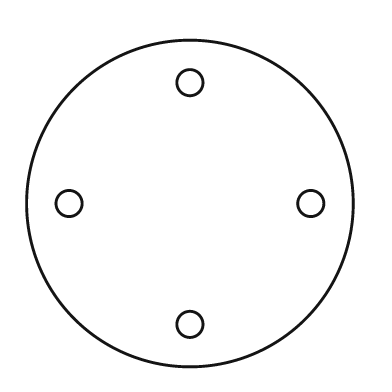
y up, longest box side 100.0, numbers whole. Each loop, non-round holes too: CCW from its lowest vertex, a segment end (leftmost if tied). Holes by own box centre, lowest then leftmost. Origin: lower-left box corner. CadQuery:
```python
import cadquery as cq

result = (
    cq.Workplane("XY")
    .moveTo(50.0, 50.0)
    .circle(50.0)
    .moveTo(50.0, 13.0)
    .circle(4.0)
    .moveTo(13.0, 50.0)
    .circle(4.0)
    .moveTo(87.0, 50.0)
    .circle(4.0)
    .moveTo(50.0, 87.0)
    .circle(4.0)
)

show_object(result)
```